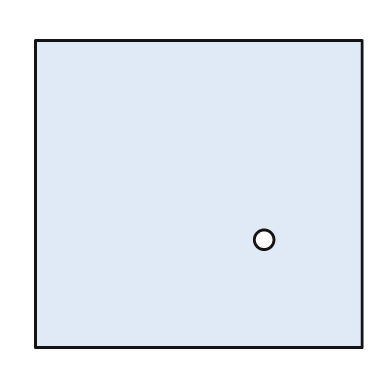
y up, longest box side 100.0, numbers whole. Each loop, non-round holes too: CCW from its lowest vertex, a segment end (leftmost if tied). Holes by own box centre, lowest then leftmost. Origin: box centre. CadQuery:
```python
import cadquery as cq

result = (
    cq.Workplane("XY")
    .moveTo(-50.0, -47.0)
    .lineTo(50.0, -47.0)
    .lineTo(50.0, 47.0)
    .lineTo(-50.0, 47.0)
    .close()
    .moveTo(20.0, -14.0)
    .circle(3.0)
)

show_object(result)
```